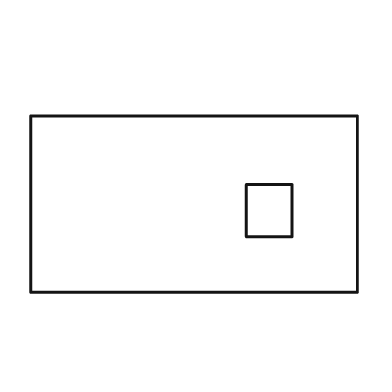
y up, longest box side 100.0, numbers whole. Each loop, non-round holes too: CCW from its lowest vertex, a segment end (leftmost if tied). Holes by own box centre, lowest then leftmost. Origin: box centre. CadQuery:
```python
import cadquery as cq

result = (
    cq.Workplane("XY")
    .moveTo(-50.0, -27.0)
    .lineTo(50.0, -27.0)
    .lineTo(50.0, 27.0)
    .lineTo(-50.0, 27.0)
    .close()
    .moveTo(16.0, -10.0)
    .lineTo(30.0, -10.0)
    .lineTo(30.0, 6.0)
    .lineTo(16.0, 6.0)
    .close()
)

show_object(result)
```